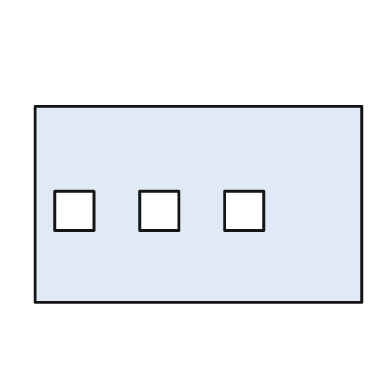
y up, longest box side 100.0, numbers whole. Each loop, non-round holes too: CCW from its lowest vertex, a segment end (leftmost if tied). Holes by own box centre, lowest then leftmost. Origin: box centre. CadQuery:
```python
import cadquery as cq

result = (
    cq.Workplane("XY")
    .moveTo(-50.0, -30.0)
    .lineTo(50.0, -30.0)
    .lineTo(50.0, 30.0)
    .lineTo(-50.0, 30.0)
    .close()
    .moveTo(-44.0, -8.0)
    .lineTo(-32.0, -8.0)
    .lineTo(-32.0, 4.0)
    .lineTo(-44.0, 4.0)
    .close()
    .moveTo(-18.0, -8.0)
    .lineTo(-6.0, -8.0)
    .lineTo(-6.0, 4.0)
    .lineTo(-18.0, 4.0)
    .close()
    .moveTo(8.0, -8.0)
    .lineTo(20.0, -8.0)
    .lineTo(20.0, 4.0)
    .lineTo(8.0, 4.0)
    .close()
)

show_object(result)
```